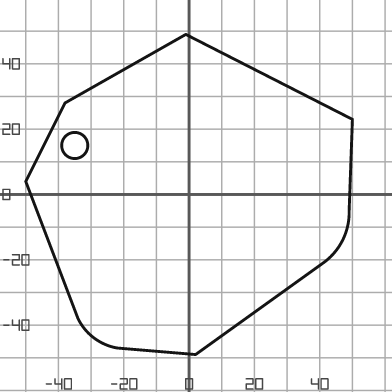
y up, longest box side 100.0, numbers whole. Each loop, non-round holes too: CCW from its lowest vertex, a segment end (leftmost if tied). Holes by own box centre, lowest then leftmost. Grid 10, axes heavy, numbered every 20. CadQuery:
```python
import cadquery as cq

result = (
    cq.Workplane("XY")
    .moveTo(2.0, -49.0)
    .lineTo(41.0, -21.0)
    .threePointArc((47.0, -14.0), (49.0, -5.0))
    .lineTo(50.0, 23.0)
    .lineTo(-1.0, 49.0)
    .lineTo(-38.0, 28.0)
    .lineTo(-50.0, 4.0)
    .lineTo(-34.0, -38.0)
    .threePointArc((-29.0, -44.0), (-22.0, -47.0))
    .close()
    .moveTo(-35.0, 15.0)
    .circle(4.0)
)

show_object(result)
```